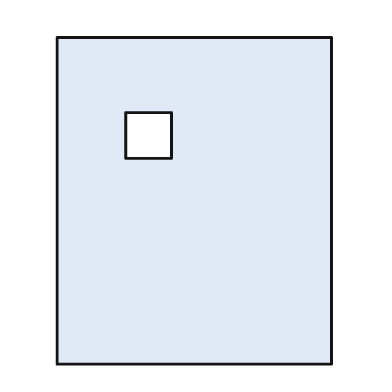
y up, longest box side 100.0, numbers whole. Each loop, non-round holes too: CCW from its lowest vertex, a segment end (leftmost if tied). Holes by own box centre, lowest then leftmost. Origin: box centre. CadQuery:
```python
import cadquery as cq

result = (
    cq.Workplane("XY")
    .moveTo(-42.0, -50.0)
    .lineTo(42.0, -50.0)
    .lineTo(42.0, 50.0)
    .lineTo(-42.0, 50.0)
    .close()
    .moveTo(-21.0, 13.0)
    .lineTo(-7.0, 13.0)
    .lineTo(-7.0, 27.0)
    .lineTo(-21.0, 27.0)
    .close()
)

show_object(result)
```